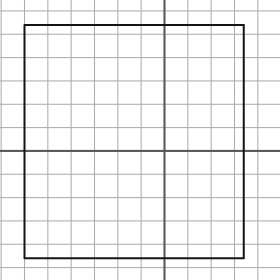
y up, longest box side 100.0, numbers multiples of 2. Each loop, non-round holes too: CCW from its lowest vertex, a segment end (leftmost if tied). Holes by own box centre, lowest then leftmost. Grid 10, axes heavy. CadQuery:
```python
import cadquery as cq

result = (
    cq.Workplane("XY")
    .moveTo(-60.0, -46.0)
    .lineTo(34.0, -46.0)
    .lineTo(34.0, 54.0)
    .lineTo(-60.0, 54.0)
    .close()
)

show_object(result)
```